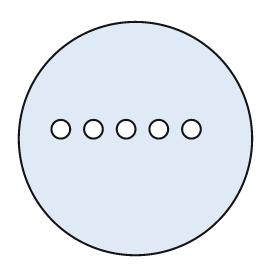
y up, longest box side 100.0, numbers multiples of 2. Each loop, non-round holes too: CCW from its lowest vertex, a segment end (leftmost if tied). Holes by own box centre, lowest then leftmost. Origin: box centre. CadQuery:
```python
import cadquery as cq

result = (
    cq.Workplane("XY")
    .moveTo(0.0, 0.0)
    .circle(50.0)
    .moveTo(-32.0, 4.0)
    .circle(4.0)
    .moveTo(-18.0, 4.0)
    .circle(4.0)
    .moveTo(-4.0, 4.0)
    .circle(4.0)
    .moveTo(10.0, 4.0)
    .circle(4.0)
    .moveTo(24.0, 4.0)
    .circle(4.0)
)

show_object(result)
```